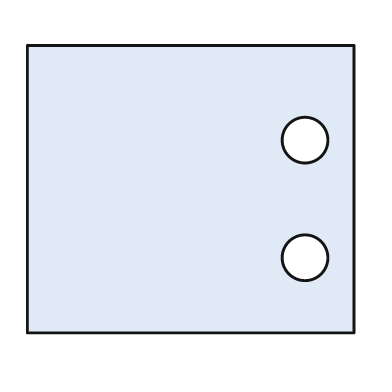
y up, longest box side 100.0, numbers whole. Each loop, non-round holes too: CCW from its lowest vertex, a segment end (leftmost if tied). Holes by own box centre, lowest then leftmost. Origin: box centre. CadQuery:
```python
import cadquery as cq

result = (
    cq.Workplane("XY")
    .moveTo(-50.0, -44.0)
    .lineTo(50.0, -44.0)
    .lineTo(50.0, 44.0)
    .lineTo(-50.0, 44.0)
    .close()
    .moveTo(35.0, -21.0)
    .circle(7.0)
    .moveTo(35.0, 15.0)
    .circle(7.0)
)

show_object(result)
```